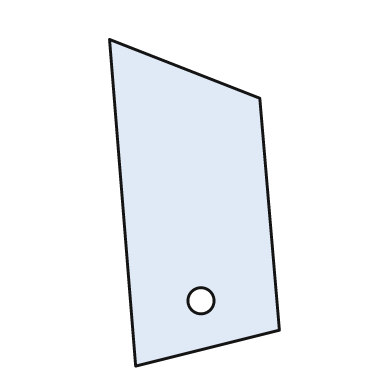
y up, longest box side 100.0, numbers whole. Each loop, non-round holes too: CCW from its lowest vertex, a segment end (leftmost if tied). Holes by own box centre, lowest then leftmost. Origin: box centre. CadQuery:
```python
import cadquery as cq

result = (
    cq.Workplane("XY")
    .moveTo(-18.0, -50.0)
    .lineTo(26.0, -39.0)
    .lineTo(20.0, 32.0)
    .lineTo(-26.0, 50.0)
    .close()
    .moveTo(2.0, -30.0)
    .circle(4.0)
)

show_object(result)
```